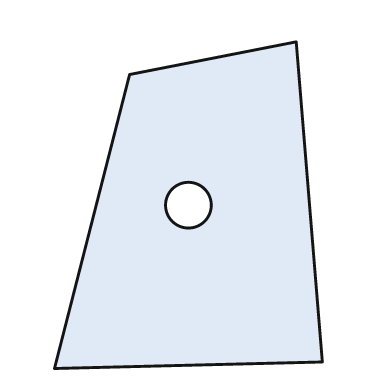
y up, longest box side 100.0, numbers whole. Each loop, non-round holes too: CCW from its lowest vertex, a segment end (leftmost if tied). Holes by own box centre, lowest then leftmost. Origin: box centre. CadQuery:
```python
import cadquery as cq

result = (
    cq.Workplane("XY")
    .moveTo(-41.0, -50.0)
    .lineTo(41.0, -48.0)
    .lineTo(33.0, 50.0)
    .lineTo(-18.0, 40.0)
    .close()
    .moveTo(0.0, 0.0)
    .circle(7.0)
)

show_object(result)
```